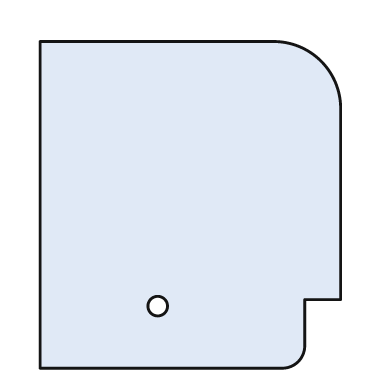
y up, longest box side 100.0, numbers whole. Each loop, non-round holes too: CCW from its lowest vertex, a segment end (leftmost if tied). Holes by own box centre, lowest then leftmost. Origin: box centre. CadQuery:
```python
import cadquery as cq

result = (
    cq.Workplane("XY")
    .moveTo(-46.0, -50.0)
    .lineTo(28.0, -50.0)
    .threePointArc((33.0, -48.0), (35.0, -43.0))
    .lineTo(35.0, -29.0)
    .lineTo(46.0, -29.0)
    .lineTo(46.0, 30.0)
    .threePointArc((40.0, 44.0), (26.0, 50.0))
    .lineTo(-46.0, 50.0)
    .close()
    .moveTo(-10.0, -31.0)
    .circle(3.0)
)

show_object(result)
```